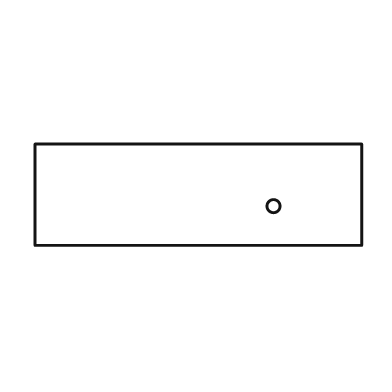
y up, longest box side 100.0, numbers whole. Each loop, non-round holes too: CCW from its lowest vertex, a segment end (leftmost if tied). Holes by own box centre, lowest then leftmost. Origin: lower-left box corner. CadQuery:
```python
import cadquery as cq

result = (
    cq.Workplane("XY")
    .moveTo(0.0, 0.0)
    .lineTo(100.0, 0.0)
    .lineTo(100.0, 31.0)
    .lineTo(0.0, 31.0)
    .close()
    .moveTo(73.0, 12.0)
    .circle(2.0)
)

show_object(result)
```